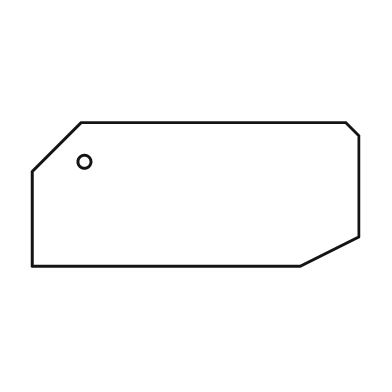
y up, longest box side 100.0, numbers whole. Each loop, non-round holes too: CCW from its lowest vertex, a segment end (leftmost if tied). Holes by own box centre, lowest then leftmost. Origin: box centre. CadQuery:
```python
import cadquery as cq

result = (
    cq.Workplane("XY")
    .moveTo(-50.0, -22.0)
    .lineTo(32.0, -22.0)
    .lineTo(50.0, -13.0)
    .lineTo(50.0, 18.0)
    .lineTo(46.0, 22.0)
    .lineTo(-35.0, 22.0)
    .lineTo(-50.0, 7.0)
    .close()
    .moveTo(-34.0, 10.0)
    .circle(2.0)
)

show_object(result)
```